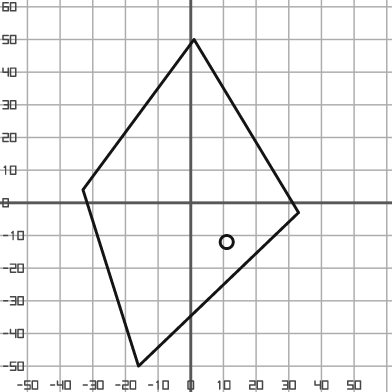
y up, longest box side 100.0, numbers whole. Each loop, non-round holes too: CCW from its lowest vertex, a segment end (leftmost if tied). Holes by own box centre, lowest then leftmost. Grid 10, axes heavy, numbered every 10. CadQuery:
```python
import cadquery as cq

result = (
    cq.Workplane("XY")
    .moveTo(-16.0, -50.0)
    .lineTo(33.0, -3.0)
    .lineTo(1.0, 50.0)
    .lineTo(-33.0, 4.0)
    .close()
    .moveTo(11.0, -12.0)
    .circle(2.0)
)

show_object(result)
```